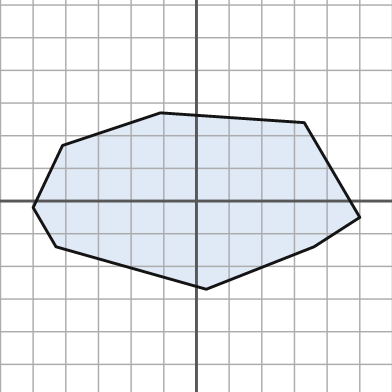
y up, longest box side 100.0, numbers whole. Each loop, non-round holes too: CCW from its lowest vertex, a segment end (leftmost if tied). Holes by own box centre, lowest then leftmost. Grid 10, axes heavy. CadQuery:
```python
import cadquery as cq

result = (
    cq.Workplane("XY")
    .moveTo(3.0, -27.0)
    .lineTo(36.0, -14.0)
    .lineTo(50.0, -5.0)
    .lineTo(33.0, 24.0)
    .lineTo(-11.0, 27.0)
    .lineTo(-41.0, 17.0)
    .lineTo(-50.0, -2.0)
    .lineTo(-43.0, -14.0)
    .close()
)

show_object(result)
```